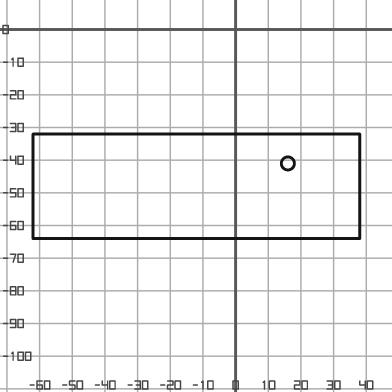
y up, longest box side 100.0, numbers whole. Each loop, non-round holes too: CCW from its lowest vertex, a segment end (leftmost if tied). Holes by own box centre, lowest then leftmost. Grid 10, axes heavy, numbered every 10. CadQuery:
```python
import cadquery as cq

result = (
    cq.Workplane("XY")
    .moveTo(-62.0, -64.0)
    .lineTo(38.0, -64.0)
    .lineTo(38.0, -32.0)
    .lineTo(-62.0, -32.0)
    .close()
    .moveTo(16.0, -41.0)
    .circle(2.0)
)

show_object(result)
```